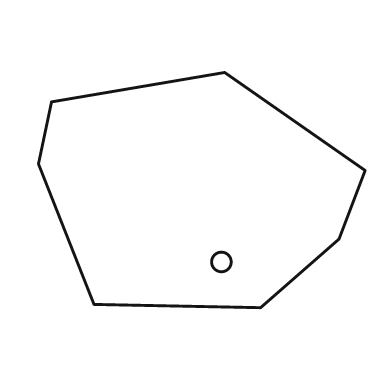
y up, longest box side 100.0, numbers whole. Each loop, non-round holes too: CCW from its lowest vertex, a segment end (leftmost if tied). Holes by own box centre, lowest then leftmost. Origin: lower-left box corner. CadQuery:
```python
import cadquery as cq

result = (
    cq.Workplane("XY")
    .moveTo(68.0, 0.0)
    .lineTo(92.0, 21.0)
    .lineTo(100.0, 42.0)
    .lineTo(57.0, 72.0)
    .lineTo(4.0, 63.0)
    .lineTo(0.0, 44.0)
    .lineTo(17.0, 1.0)
    .close()
    .moveTo(56.0, 14.0)
    .circle(3.0)
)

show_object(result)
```